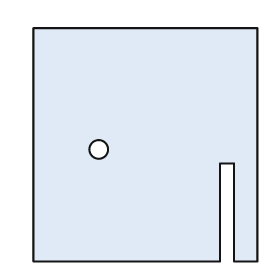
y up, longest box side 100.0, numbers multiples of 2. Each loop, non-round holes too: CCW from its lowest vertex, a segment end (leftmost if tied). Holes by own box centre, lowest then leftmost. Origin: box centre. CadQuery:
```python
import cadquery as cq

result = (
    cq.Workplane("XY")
    .moveTo(-48.0, -50.0)
    .lineTo(32.0, -50.0)
    .lineTo(32.0, -8.0)
    .lineTo(38.0, -8.0)
    .lineTo(38.0, -50.0)
    .lineTo(48.0, -50.0)
    .lineTo(48.0, 50.0)
    .lineTo(-48.0, 50.0)
    .close()
    .moveTo(-20.0, -2.0)
    .circle(4.0)
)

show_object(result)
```